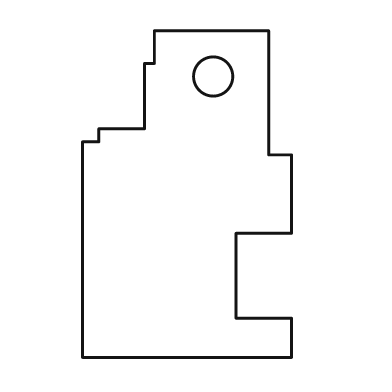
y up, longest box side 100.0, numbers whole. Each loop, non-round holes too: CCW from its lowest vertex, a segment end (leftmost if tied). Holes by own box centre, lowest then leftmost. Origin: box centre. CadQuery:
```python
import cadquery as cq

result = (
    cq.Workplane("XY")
    .moveTo(-32.0, -50.0)
    .lineTo(32.0, -50.0)
    .lineTo(32.0, -38.0)
    .lineTo(15.0, -38.0)
    .lineTo(15.0, -12.0)
    .lineTo(32.0, -12.0)
    .lineTo(32.0, 12.0)
    .lineTo(25.0, 12.0)
    .lineTo(25.0, 50.0)
    .lineTo(-10.0, 50.0)
    .lineTo(-10.0, 40.0)
    .lineTo(-13.0, 40.0)
    .lineTo(-13.0, 20.0)
    .lineTo(-27.0, 20.0)
    .lineTo(-27.0, 16.0)
    .lineTo(-32.0, 16.0)
    .close()
    .moveTo(8.0, 36.0)
    .circle(6.0)
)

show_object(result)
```